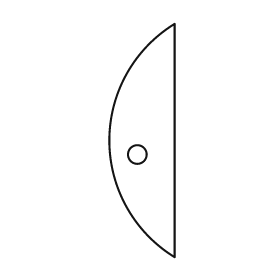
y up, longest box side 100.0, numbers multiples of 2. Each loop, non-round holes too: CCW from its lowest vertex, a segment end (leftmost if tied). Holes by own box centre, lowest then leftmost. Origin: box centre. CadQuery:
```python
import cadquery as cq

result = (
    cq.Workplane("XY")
    .moveTo(14.0, -50.0)
    .lineTo(14.0, 50.0)
    .threePointArc((-14.0, 0.0), (14.0, -50.0))
    .close()
    .moveTo(-2.0, -6.0)
    .circle(4.0)
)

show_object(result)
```